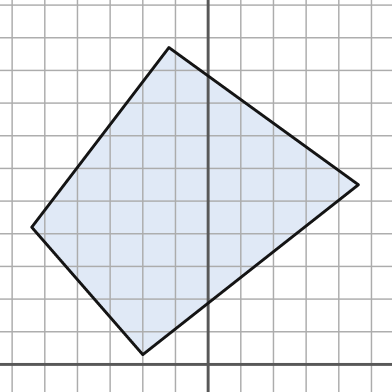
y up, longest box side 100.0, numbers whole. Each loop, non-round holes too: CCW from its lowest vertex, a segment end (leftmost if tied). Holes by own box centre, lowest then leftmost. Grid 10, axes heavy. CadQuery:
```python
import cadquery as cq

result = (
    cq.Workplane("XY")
    .moveTo(-20.0, 3.0)
    .lineTo(46.0, 55.0)
    .lineTo(-12.0, 97.0)
    .lineTo(-54.0, 42.0)
    .close()
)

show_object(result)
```